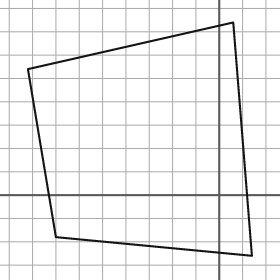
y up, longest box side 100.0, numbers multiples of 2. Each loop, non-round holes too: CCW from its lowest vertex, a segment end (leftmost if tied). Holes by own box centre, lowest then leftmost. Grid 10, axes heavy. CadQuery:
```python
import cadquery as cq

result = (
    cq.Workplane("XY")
    .moveTo(14.0, -26.0)
    .lineTo(6.0, 74.0)
    .lineTo(-82.0, 54.0)
    .lineTo(-70.0, -18.0)
    .close()
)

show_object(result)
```